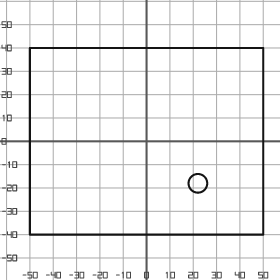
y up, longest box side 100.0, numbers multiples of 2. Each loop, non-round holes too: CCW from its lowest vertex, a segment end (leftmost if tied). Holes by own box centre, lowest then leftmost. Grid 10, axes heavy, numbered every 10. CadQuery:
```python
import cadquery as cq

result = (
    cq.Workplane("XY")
    .moveTo(-50.0, -40.0)
    .lineTo(50.0, -40.0)
    .lineTo(50.0, 40.0)
    .lineTo(-50.0, 40.0)
    .close()
    .moveTo(22.0, -18.0)
    .circle(4.0)
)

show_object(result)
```